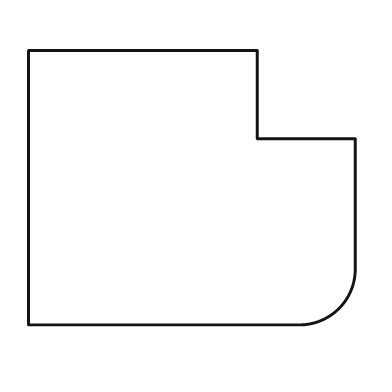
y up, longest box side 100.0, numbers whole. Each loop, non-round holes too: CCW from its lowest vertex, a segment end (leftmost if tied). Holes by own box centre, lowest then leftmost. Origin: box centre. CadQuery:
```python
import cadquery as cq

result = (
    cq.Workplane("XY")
    .moveTo(-50.0, -42.0)
    .lineTo(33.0, -42.0)
    .threePointArc((45.0, -37.0), (50.0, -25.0))
    .lineTo(50.0, 15.0)
    .lineTo(20.0, 15.0)
    .lineTo(20.0, 42.0)
    .lineTo(-50.0, 42.0)
    .close()
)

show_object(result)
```